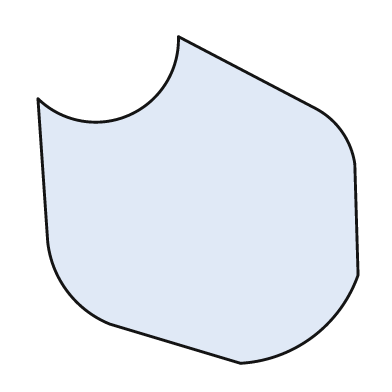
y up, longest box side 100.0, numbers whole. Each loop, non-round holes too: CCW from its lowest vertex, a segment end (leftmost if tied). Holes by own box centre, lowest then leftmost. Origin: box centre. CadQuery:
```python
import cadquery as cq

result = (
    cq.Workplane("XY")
    .moveTo(13.0, -50.0)
    .threePointArc((35.0, -42.0), (49.0, -23.0))
    .lineTo(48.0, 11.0)
    .threePointArc((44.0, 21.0), (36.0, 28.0))
    .lineTo(-6.0, 50.0)
    .threePointArc((-21.0, 26.0), (-49.0, 31.0))
    .lineTo(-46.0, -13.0)
    .threePointArc((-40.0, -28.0), (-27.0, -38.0))
    .close()
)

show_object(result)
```